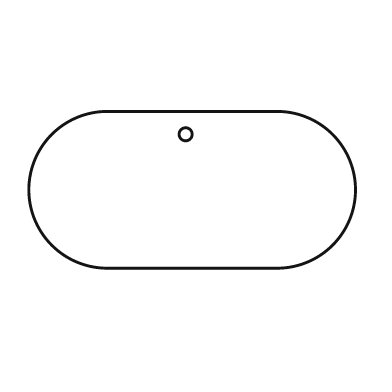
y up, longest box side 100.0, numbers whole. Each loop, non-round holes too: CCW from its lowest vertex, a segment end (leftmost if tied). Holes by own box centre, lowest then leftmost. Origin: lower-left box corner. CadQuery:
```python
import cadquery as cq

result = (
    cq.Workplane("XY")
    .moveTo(24.0, 0.0)
    .lineTo(76.0, 0.0)
    .threePointArc((100.0, 24.0), (76.0, 48.0))
    .lineTo(24.0, 48.0)
    .threePointArc((0.0, 24.0), (24.0, 0.0))
    .close()
    .moveTo(48.0, 41.0)
    .circle(2.0)
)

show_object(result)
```